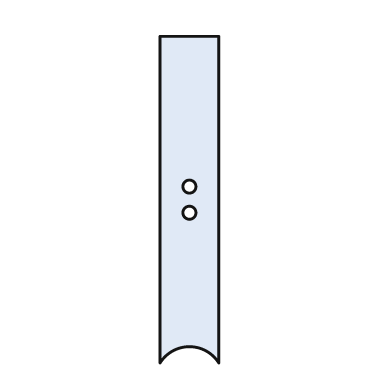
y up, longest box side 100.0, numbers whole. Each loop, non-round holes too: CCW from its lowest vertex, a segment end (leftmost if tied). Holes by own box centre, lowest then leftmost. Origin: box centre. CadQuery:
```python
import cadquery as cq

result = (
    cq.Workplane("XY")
    .moveTo(-9.0, -50.0)
    .threePointArc((0.0, -45.0), (9.0, -50.0))
    .lineTo(9.0, 50.0)
    .lineTo(-9.0, 50.0)
    .close()
    .moveTo(0.0, -4.0)
    .circle(2.0)
    .moveTo(0.0, 4.0)
    .circle(2.0)
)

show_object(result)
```